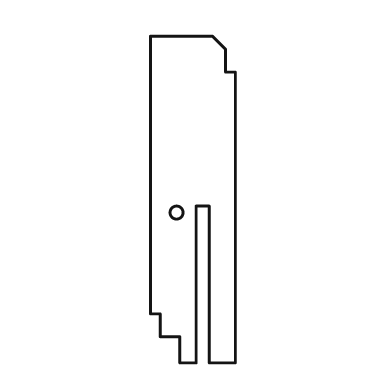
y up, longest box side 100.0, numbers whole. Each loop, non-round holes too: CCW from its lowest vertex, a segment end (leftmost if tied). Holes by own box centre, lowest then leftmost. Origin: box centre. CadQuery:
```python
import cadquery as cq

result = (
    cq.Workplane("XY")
    .moveTo(-4.0, -50.0)
    .lineTo(1.0, -50.0)
    .lineTo(1.0, -2.0)
    .lineTo(5.0, -2.0)
    .lineTo(5.0, -50.0)
    .lineTo(13.0, -50.0)
    .lineTo(13.0, 39.0)
    .lineTo(10.0, 39.0)
    .lineTo(10.0, 46.0)
    .lineTo(6.0, 50.0)
    .lineTo(-13.0, 50.0)
    .lineTo(-13.0, -35.0)
    .lineTo(-10.0, -35.0)
    .lineTo(-10.0, -42.0)
    .lineTo(-4.0, -42.0)
    .close()
    .moveTo(-5.0, -4.0)
    .circle(2.0)
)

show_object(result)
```